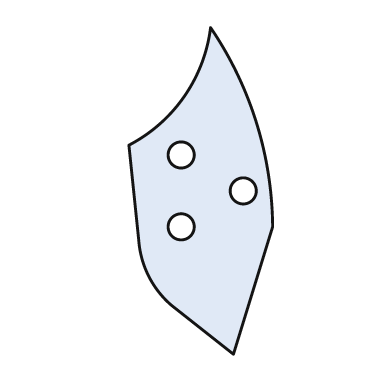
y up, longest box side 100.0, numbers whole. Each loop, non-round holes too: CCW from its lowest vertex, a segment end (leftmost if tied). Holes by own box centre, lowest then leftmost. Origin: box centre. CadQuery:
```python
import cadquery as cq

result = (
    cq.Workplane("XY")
    .moveTo(10.0, -50.0)
    .lineTo(22.0, -11.0)
    .threePointArc((17.0, 21.0), (3.0, 50.0))
    .threePointArc((-5.0, 29.0), (-22.0, 14.0))
    .lineTo(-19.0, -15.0)
    .threePointArc((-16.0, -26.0), (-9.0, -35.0))
    .close()
    .moveTo(-6.0, -11.0)
    .circle(4.0)
    .moveTo(13.0, 0.0)
    .circle(4.0)
    .moveTo(-6.0, 11.0)
    .circle(4.0)
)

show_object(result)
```